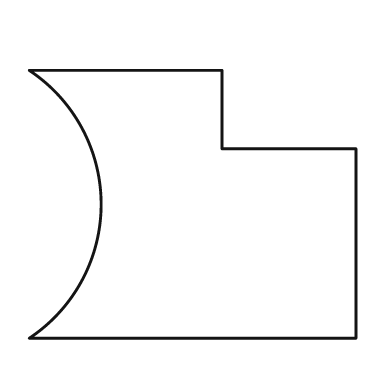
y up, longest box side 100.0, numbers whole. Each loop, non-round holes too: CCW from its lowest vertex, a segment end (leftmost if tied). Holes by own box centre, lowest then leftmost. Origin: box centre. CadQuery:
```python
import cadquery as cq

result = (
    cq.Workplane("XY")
    .moveTo(-50.0, -41.0)
    .lineTo(50.0, -41.0)
    .lineTo(50.0, 17.0)
    .lineTo(9.0, 17.0)
    .lineTo(9.0, 41.0)
    .lineTo(-50.0, 41.0)
    .threePointArc((-28.0, 0.0), (-50.0, -41.0))
    .close()
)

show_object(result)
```